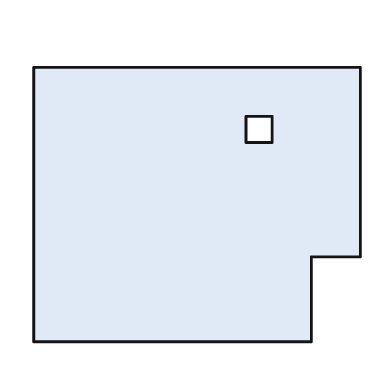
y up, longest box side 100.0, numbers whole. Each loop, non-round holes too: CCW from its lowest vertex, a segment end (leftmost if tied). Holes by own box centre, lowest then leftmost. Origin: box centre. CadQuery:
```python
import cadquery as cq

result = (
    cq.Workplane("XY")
    .moveTo(-50.0, -42.0)
    .lineTo(35.0, -42.0)
    .lineTo(35.0, -16.0)
    .lineTo(50.0, -16.0)
    .lineTo(50.0, 42.0)
    .lineTo(-50.0, 42.0)
    .close()
    .moveTo(15.0, 19.0)
    .lineTo(23.0, 19.0)
    .lineTo(23.0, 27.0)
    .lineTo(15.0, 27.0)
    .close()
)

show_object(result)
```